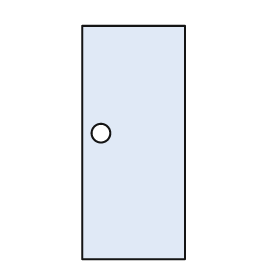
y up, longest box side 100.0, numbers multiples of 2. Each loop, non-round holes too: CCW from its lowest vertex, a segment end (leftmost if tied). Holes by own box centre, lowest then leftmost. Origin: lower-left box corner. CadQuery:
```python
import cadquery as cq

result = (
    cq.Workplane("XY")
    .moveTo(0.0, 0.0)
    .lineTo(44.0, 0.0)
    .lineTo(44.0, 100.0)
    .lineTo(0.0, 100.0)
    .close()
    .moveTo(8.0, 54.0)
    .circle(4.0)
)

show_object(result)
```